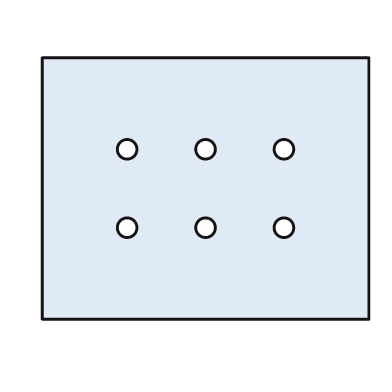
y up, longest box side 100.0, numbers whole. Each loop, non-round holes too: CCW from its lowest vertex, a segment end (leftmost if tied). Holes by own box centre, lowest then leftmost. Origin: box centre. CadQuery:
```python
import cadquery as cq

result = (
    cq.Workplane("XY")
    .moveTo(-50.0, -40.0)
    .lineTo(50.0, -40.0)
    .lineTo(50.0, 40.0)
    .lineTo(-50.0, 40.0)
    .close()
    .moveTo(-24.0, -12.0)
    .circle(3.0)
    .moveTo(0.0, -12.0)
    .circle(3.0)
    .moveTo(24.0, -12.0)
    .circle(3.0)
    .moveTo(-24.0, 12.0)
    .circle(3.0)
    .moveTo(0.0, 12.0)
    .circle(3.0)
    .moveTo(24.0, 12.0)
    .circle(3.0)
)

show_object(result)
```